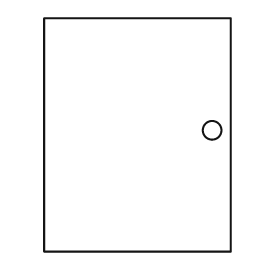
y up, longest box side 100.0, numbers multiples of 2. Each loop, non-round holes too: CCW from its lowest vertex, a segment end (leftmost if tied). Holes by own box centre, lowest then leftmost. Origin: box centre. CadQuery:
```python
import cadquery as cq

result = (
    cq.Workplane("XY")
    .moveTo(-40.0, -50.0)
    .lineTo(40.0, -50.0)
    .lineTo(40.0, 50.0)
    .lineTo(-40.0, 50.0)
    .close()
    .moveTo(32.0, 2.0)
    .circle(4.0)
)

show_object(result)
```